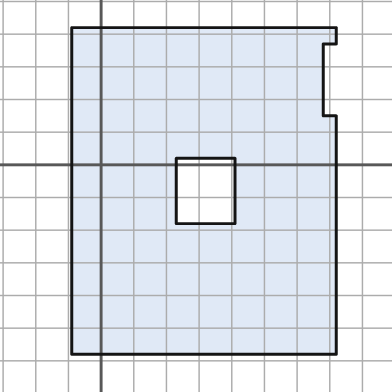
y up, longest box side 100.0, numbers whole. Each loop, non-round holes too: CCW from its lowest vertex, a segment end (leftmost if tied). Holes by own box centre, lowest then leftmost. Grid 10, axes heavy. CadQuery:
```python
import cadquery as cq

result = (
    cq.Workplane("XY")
    .moveTo(-9.0, -58.0)
    .lineTo(72.0, -58.0)
    .lineTo(72.0, 15.0)
    .lineTo(68.0, 15.0)
    .lineTo(68.0, 37.0)
    .lineTo(72.0, 37.0)
    .lineTo(72.0, 42.0)
    .lineTo(-9.0, 42.0)
    .close()
    .moveTo(23.0, -18.0)
    .lineTo(41.0, -18.0)
    .lineTo(41.0, 2.0)
    .lineTo(23.0, 2.0)
    .close()
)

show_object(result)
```